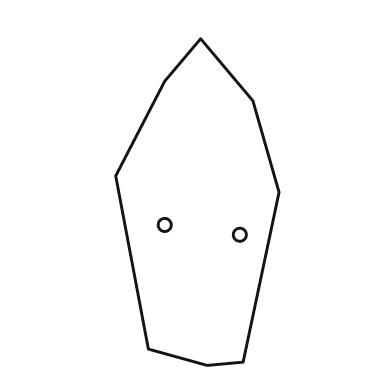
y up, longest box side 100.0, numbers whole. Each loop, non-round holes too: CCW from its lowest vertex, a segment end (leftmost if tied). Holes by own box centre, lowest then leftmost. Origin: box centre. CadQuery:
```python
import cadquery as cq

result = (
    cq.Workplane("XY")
    .moveTo(3.0, -50.0)
    .lineTo(14.0, -49.0)
    .lineTo(25.0, 3.0)
    .lineTo(17.0, 31.0)
    .lineTo(1.0, 50.0)
    .lineTo(-10.0, 37.0)
    .lineTo(-25.0, 8.0)
    .lineTo(-15.0, -45.0)
    .close()
    .moveTo(13.0, -10.0)
    .circle(2.0)
    .moveTo(-10.0, -7.0)
    .circle(2.0)
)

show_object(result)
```